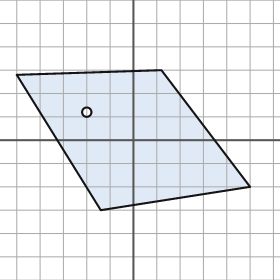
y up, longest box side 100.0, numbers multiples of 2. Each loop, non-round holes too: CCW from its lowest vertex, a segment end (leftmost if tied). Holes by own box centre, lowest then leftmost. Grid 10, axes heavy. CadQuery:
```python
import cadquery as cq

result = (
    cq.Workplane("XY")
    .moveTo(-14.0, -30.0)
    .lineTo(50.0, -20.0)
    .lineTo(12.0, 30.0)
    .lineTo(-50.0, 28.0)
    .close()
    .moveTo(-20.0, 12.0)
    .circle(2.0)
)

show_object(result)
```